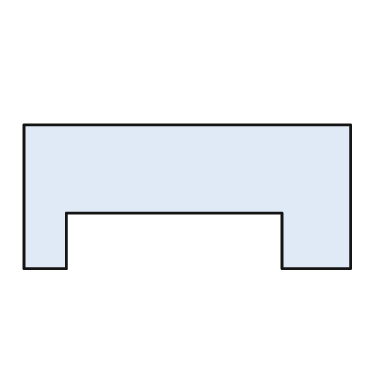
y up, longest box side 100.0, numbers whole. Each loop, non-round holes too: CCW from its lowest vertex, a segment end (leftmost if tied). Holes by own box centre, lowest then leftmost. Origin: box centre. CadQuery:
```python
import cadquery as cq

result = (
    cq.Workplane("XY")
    .moveTo(-50.0, -22.0)
    .lineTo(-37.0, -22.0)
    .lineTo(-37.0, -5.0)
    .lineTo(29.0, -5.0)
    .lineTo(29.0, -22.0)
    .lineTo(50.0, -22.0)
    .lineTo(50.0, 22.0)
    .lineTo(-50.0, 22.0)
    .close()
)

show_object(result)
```